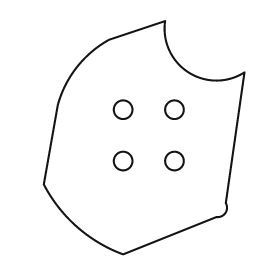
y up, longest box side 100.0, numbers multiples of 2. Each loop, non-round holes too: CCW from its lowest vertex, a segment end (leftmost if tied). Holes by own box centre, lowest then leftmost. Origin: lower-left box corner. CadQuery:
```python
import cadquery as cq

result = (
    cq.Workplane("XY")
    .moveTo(34.0, 0.0)
    .lineTo(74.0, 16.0)
    .threePointArc((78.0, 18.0), (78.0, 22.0))
    .lineTo(86.0, 78.0)
    .threePointArc((62.0, 78.0), (52.0, 100.0))
    .lineTo(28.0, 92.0)
    .threePointArc((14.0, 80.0), (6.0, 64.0))
    .lineTo(0.0, 30.0)
    .threePointArc((14.0, 12.0), (34.0, 0.0))
    .close()
    .moveTo(34.0, 40.0)
    .circle(4.0)
    .moveTo(56.0, 40.0)
    .circle(4.0)
    .moveTo(34.0, 62.0)
    .circle(4.0)
    .moveTo(56.0, 62.0)
    .circle(4.0)
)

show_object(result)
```